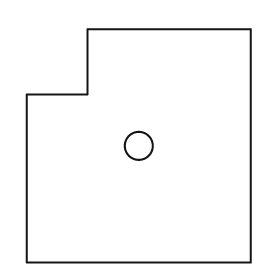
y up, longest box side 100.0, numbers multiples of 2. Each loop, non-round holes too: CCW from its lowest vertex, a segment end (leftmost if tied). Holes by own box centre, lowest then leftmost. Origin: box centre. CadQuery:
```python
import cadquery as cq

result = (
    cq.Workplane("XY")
    .moveTo(-48.0, -50.0)
    .lineTo(48.0, -50.0)
    .lineTo(48.0, 50.0)
    .lineTo(-22.0, 50.0)
    .lineTo(-22.0, 22.0)
    .lineTo(-48.0, 22.0)
    .close()
    .moveTo(0.0, 0.0)
    .circle(6.0)
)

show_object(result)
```